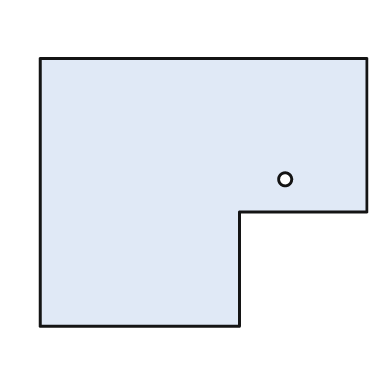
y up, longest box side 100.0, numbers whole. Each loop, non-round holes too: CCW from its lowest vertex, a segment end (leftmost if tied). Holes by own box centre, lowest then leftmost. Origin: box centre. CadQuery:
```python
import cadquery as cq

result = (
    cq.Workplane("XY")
    .moveTo(-50.0, -41.0)
    .lineTo(11.0, -41.0)
    .lineTo(11.0, -6.0)
    .lineTo(50.0, -6.0)
    .lineTo(50.0, 41.0)
    .lineTo(-50.0, 41.0)
    .close()
    .moveTo(25.0, 4.0)
    .circle(2.0)
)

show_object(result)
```